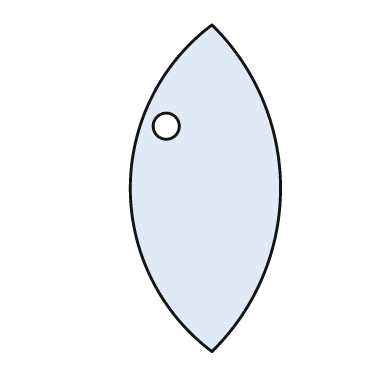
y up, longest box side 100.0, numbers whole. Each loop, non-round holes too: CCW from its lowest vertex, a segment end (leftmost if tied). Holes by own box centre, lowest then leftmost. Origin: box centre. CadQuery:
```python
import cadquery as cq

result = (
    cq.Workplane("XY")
    .moveTo(2.0, -50.0)
    .threePointArc((23.0, 0.0), (2.0, 50.0))
    .threePointArc((-23.0, 0.0), (2.0, -50.0))
    .close()
    .moveTo(-12.0, 19.0)
    .circle(4.0)
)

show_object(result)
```